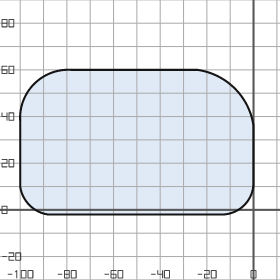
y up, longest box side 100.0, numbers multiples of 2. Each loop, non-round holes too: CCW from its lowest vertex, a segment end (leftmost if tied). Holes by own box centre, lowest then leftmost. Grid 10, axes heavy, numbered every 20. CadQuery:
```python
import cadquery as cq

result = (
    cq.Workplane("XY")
    .moveTo(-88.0, -2.0)
    .lineTo(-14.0, -2.0)
    .threePointArc((-4.0, 2.0), (0.0, 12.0))
    .lineTo(0.0, 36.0)
    .threePointArc((-8.0, 52.0), (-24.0, 60.0))
    .lineTo(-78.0, 60.0)
    .threePointArc((-94.0, 54.0), (-100.0, 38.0))
    .lineTo(-100.0, 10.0)
    .threePointArc((-96.0, 2.0), (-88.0, -2.0))
    .close()
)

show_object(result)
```